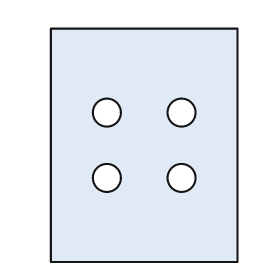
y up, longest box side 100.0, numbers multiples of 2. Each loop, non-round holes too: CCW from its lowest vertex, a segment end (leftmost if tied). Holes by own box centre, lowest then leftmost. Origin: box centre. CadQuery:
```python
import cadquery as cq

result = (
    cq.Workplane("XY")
    .moveTo(-40.0, -50.0)
    .lineTo(40.0, -50.0)
    .lineTo(40.0, 50.0)
    .lineTo(-40.0, 50.0)
    .close()
    .moveTo(-16.0, -14.0)
    .circle(6.0)
    .moveTo(16.0, -14.0)
    .circle(6.0)
    .moveTo(-16.0, 14.0)
    .circle(6.0)
    .moveTo(16.0, 14.0)
    .circle(6.0)
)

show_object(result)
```